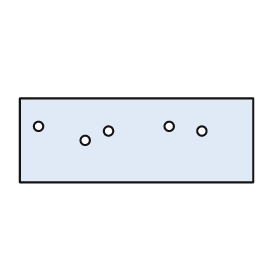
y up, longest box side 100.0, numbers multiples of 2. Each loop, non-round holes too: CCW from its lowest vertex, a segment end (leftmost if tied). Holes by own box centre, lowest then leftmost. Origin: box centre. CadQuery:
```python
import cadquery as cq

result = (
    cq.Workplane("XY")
    .moveTo(-50.0, -18.0)
    .lineTo(50.0, -18.0)
    .lineTo(50.0, 18.0)
    .lineTo(-50.0, 18.0)
    .close()
    .moveTo(-22.0, 0.0)
    .circle(2.0)
    .moveTo(-12.0, 4.0)
    .circle(2.0)
    .moveTo(28.0, 4.0)
    .circle(2.0)
    .moveTo(-42.0, 6.0)
    .circle(2.0)
    .moveTo(14.0, 6.0)
    .circle(2.0)
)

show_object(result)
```